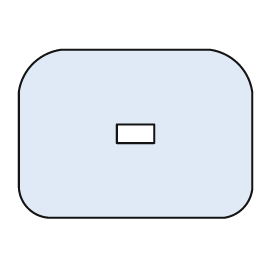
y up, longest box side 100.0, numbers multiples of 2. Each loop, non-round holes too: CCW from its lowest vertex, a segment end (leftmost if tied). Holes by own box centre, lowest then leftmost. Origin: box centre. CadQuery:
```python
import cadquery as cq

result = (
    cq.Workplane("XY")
    .moveTo(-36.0, -36.0)
    .lineTo(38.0, -36.0)
    .threePointArc((46.0, -32.0), (50.0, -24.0))
    .lineTo(50.0, 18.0)
    .threePointArc((44.0, 30.0), (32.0, 36.0))
    .lineTo(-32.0, 36.0)
    .threePointArc((-44.0, 30.0), (-50.0, 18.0))
    .lineTo(-50.0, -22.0)
    .threePointArc((-46.0, -32.0), (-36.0, -36.0))
    .close()
    .moveTo(-8.0, -4.0)
    .lineTo(8.0, -4.0)
    .lineTo(8.0, 4.0)
    .lineTo(-8.0, 4.0)
    .close()
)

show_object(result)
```